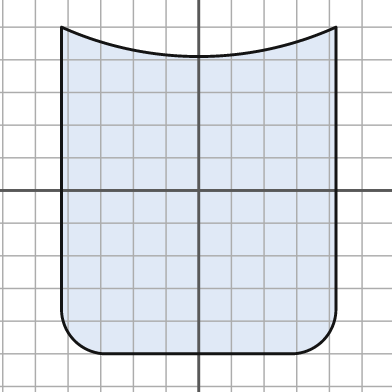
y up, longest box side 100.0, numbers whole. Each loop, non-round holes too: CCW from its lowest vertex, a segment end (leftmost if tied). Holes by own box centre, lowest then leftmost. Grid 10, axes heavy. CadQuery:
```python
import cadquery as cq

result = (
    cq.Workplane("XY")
    .moveTo(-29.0, -50.0)
    .lineTo(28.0, -50.0)
    .threePointArc((38.0, -46.0), (42.0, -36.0))
    .lineTo(42.0, 50.0)
    .threePointArc((0.0, 41.0), (-42.0, 50.0))
    .lineTo(-42.0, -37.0)
    .threePointArc((-38.0, -46.0), (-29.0, -50.0))
    .close()
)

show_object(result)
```